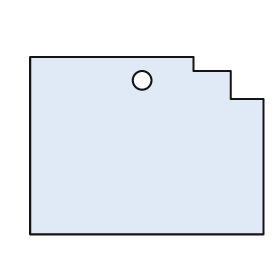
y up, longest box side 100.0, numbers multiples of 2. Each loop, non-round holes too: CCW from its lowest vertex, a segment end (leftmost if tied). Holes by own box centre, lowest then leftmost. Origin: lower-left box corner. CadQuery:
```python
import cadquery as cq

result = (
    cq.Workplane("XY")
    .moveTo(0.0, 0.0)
    .lineTo(100.0, 0.0)
    .lineTo(100.0, 58.0)
    .lineTo(86.0, 58.0)
    .lineTo(86.0, 70.0)
    .lineTo(70.0, 70.0)
    .lineTo(70.0, 76.0)
    .lineTo(0.0, 76.0)
    .close()
    .moveTo(48.0, 66.0)
    .circle(4.0)
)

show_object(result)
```